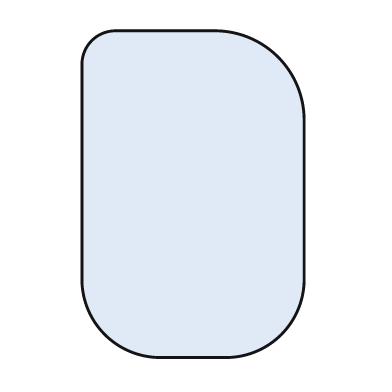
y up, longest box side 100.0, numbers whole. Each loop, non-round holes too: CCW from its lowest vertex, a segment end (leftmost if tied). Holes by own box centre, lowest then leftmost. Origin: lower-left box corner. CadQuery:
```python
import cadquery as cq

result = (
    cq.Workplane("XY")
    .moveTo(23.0, 0.0)
    .lineTo(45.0, 0.0)
    .threePointArc((61.0, 7.0), (68.0, 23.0))
    .lineTo(68.0, 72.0)
    .threePointArc((60.0, 92.0), (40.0, 100.0))
    .lineTo(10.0, 100.0)
    .threePointArc((3.0, 97.0), (0.0, 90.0))
    .lineTo(0.0, 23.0)
    .threePointArc((7.0, 7.0), (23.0, 0.0))
    .close()
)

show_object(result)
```